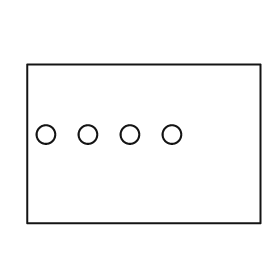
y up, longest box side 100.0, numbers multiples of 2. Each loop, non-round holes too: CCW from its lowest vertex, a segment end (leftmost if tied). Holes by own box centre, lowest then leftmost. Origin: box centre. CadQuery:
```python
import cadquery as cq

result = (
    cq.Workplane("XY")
    .moveTo(-50.0, -34.0)
    .lineTo(50.0, -34.0)
    .lineTo(50.0, 34.0)
    .lineTo(-50.0, 34.0)
    .close()
    .moveTo(-42.0, 4.0)
    .circle(4.0)
    .moveTo(-24.0, 4.0)
    .circle(4.0)
    .moveTo(-6.0, 4.0)
    .circle(4.0)
    .moveTo(12.0, 4.0)
    .circle(4.0)
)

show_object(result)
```